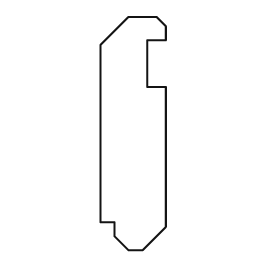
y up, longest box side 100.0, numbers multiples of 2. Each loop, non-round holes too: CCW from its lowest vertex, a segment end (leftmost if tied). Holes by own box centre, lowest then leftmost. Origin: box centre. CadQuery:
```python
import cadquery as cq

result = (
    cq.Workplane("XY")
    .moveTo(-2.0, -50.0)
    .lineTo(4.0, -50.0)
    .lineTo(14.0, -40.0)
    .lineTo(14.0, 20.0)
    .lineTo(6.0, 20.0)
    .lineTo(6.0, 40.0)
    .lineTo(14.0, 40.0)
    .lineTo(14.0, 46.0)
    .lineTo(10.0, 50.0)
    .lineTo(-2.0, 50.0)
    .lineTo(-14.0, 38.0)
    .lineTo(-14.0, -38.0)
    .lineTo(-8.0, -38.0)
    .lineTo(-8.0, -44.0)
    .close()
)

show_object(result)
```